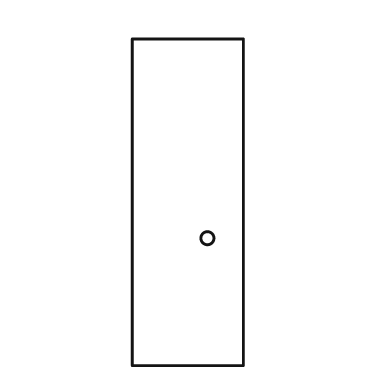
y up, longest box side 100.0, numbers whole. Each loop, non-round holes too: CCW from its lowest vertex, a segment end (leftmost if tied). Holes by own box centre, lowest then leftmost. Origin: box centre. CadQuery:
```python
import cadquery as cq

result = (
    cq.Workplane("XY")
    .moveTo(-17.0, -50.0)
    .lineTo(17.0, -50.0)
    .lineTo(17.0, 50.0)
    .lineTo(-17.0, 50.0)
    .close()
    .moveTo(6.0, -11.0)
    .circle(2.0)
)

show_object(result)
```